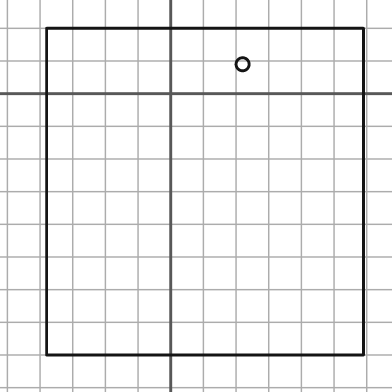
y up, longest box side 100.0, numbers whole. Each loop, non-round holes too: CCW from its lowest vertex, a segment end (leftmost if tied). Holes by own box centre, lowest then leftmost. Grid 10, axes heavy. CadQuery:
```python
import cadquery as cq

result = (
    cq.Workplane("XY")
    .moveTo(-38.0, -80.0)
    .lineTo(59.0, -80.0)
    .lineTo(59.0, 20.0)
    .lineTo(-38.0, 20.0)
    .close()
    .moveTo(22.0, 9.0)
    .circle(2.0)
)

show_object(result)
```